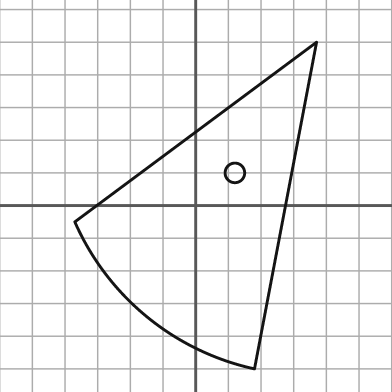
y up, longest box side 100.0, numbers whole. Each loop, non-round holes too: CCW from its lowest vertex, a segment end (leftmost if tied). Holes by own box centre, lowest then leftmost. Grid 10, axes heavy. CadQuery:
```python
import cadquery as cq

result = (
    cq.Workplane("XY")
    .moveTo(18.0, -50.0)
    .lineTo(37.0, 50.0)
    .lineTo(-37.0, -5.0)
    .threePointArc((-15.0, -34.0), (18.0, -50.0))
    .close()
    .moveTo(12.0, 10.0)
    .circle(3.0)
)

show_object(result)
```